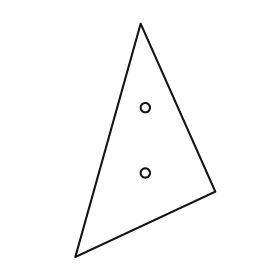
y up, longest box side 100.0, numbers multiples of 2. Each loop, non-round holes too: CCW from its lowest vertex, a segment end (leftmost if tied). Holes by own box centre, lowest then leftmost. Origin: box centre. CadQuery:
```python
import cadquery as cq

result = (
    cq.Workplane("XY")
    .moveTo(-30.0, -50.0)
    .lineTo(30.0, -22.0)
    .lineTo(-2.0, 50.0)
    .close()
    .moveTo(0.0, -14.0)
    .circle(2.0)
    .moveTo(0.0, 14.0)
    .circle(2.0)
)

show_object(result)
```